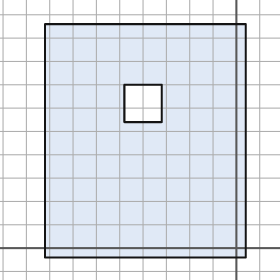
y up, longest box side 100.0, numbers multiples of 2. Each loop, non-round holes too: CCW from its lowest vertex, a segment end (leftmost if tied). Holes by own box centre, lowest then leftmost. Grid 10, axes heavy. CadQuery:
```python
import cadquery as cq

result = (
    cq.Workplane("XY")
    .moveTo(-82.0, -4.0)
    .lineTo(4.0, -4.0)
    .lineTo(4.0, 96.0)
    .lineTo(-82.0, 96.0)
    .close()
    .moveTo(-48.0, 54.0)
    .lineTo(-32.0, 54.0)
    .lineTo(-32.0, 70.0)
    .lineTo(-48.0, 70.0)
    .close()
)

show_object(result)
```